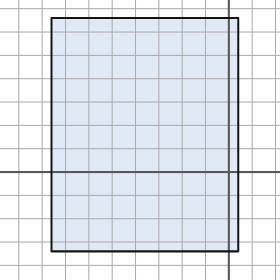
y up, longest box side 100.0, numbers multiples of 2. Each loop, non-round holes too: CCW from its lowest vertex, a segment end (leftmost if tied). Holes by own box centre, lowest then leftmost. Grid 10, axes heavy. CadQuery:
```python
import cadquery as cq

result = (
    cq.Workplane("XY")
    .moveTo(-76.0, -34.0)
    .lineTo(4.0, -34.0)
    .lineTo(4.0, 66.0)
    .lineTo(-76.0, 66.0)
    .close()
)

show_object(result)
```